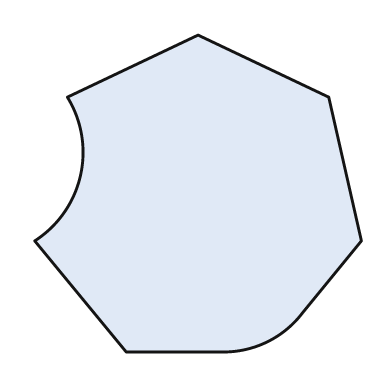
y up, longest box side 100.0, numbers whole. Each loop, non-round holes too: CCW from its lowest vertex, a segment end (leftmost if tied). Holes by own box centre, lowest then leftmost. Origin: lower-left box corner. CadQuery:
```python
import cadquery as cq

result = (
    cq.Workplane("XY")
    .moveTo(28.0, 0.0)
    .lineTo(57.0, 0.0)
    .threePointArc((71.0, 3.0), (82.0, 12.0))
    .lineTo(100.0, 34.0)
    .lineTo(90.0, 78.0)
    .lineTo(50.0, 97.0)
    .lineTo(10.0, 78.0)
    .threePointArc((14.0, 54.0), (0.0, 34.0))
    .close()
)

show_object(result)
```